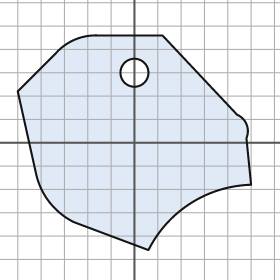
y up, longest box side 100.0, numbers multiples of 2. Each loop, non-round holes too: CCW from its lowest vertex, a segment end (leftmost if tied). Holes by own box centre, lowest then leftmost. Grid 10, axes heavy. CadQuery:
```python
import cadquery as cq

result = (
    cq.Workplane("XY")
    .moveTo(6.0, -46.0)
    .threePointArc((24.0, -26.0), (50.0, -18.0))
    .lineTo(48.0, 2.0)
    .threePointArc((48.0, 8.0), (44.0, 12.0))
    .lineTo(12.0, 46.0)
    .lineTo(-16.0, 46.0)
    .threePointArc((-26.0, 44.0), (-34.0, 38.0))
    .lineTo(-50.0, 22.0)
    .lineTo(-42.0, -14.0)
    .threePointArc((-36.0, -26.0), (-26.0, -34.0))
    .close()
    .moveTo(0.0, 30.0)
    .circle(6.0)
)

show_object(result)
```